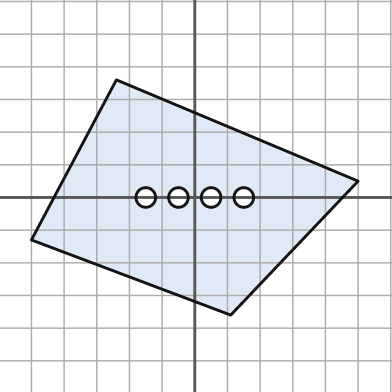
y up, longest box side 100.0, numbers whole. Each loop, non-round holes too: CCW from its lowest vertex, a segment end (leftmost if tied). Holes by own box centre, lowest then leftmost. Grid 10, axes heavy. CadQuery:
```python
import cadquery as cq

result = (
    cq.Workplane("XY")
    .moveTo(11.0, -36.0)
    .lineTo(50.0, 5.0)
    .lineTo(-24.0, 36.0)
    .lineTo(-50.0, -13.0)
    .close()
    .moveTo(-15.0, 0.0)
    .circle(3.0)
    .moveTo(-5.0, 0.0)
    .circle(3.0)
    .moveTo(5.0, 0.0)
    .circle(3.0)
    .moveTo(15.0, 0.0)
    .circle(3.0)
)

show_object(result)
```